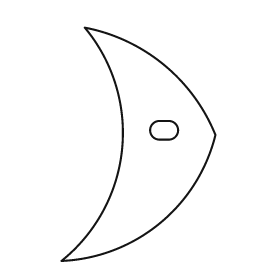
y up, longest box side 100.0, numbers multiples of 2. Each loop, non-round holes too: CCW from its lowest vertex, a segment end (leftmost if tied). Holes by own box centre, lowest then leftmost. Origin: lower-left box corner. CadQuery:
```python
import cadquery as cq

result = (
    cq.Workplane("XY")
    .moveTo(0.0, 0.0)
    .threePointArc((42.0, 16.0), (66.0, 54.0))
    .threePointArc((44.0, 84.0), (10.0, 100.0))
    .threePointArc((26.0, 48.0), (0.0, 0.0))
    .close()
    .moveTo(42.0, 52.0)
    .lineTo(46.0, 52.0)
    .threePointArc((50.0, 56.0), (46.0, 60.0))
    .lineTo(42.0, 60.0)
    .threePointArc((38.0, 56.0), (42.0, 52.0))
    .close()
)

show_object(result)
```